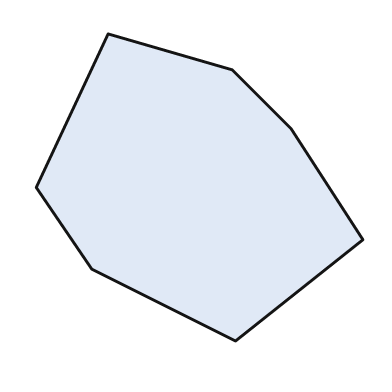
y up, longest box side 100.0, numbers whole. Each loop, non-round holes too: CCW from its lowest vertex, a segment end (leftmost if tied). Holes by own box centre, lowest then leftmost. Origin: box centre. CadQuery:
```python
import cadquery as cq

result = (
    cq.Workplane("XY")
    .moveTo(11.0, -47.0)
    .lineTo(50.0, -16.0)
    .lineTo(28.0, 18.0)
    .lineTo(10.0, 36.0)
    .lineTo(-28.0, 47.0)
    .lineTo(-50.0, 0.0)
    .lineTo(-33.0, -25.0)
    .close()
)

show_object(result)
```